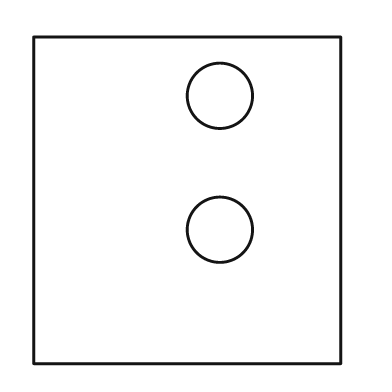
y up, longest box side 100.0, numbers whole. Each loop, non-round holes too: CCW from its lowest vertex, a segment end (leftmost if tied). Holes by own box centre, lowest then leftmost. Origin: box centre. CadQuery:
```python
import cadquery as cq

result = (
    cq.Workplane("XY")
    .moveTo(-47.0, -50.0)
    .lineTo(47.0, -50.0)
    .lineTo(47.0, 50.0)
    .lineTo(-47.0, 50.0)
    .close()
    .moveTo(10.0, -9.0)
    .circle(10.0)
    .moveTo(10.0, 32.0)
    .circle(10.0)
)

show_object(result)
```